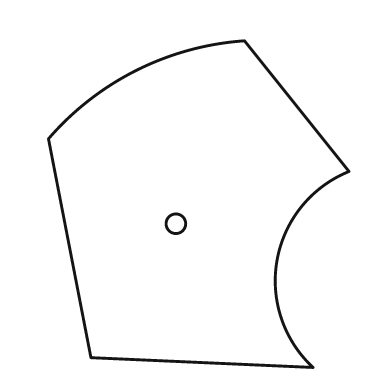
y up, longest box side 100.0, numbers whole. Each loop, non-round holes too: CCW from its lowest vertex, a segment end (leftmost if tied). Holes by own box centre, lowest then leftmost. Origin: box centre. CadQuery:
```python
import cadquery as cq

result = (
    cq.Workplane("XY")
    .moveTo(35.0, -50.0)
    .threePointArc((24.0, -17.0), (46.0, 10.0))
    .lineTo(14.0, 50.0)
    .threePointArc((-19.0, 41.0), (-46.0, 20.0))
    .lineTo(-33.0, -47.0)
    .close()
    .moveTo(-7.0, -6.0)
    .circle(3.0)
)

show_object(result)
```